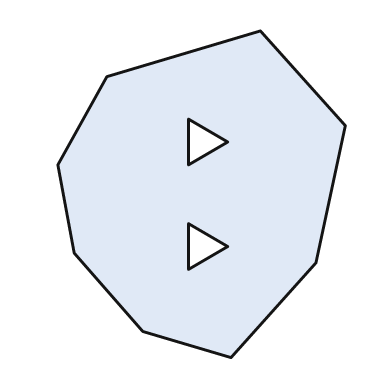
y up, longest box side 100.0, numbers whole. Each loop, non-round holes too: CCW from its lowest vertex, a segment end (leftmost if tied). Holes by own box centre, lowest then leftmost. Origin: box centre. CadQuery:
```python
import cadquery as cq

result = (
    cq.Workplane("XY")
    .moveTo(9.0, -50.0)
    .lineTo(35.0, -21.0)
    .lineTo(44.0, 21.0)
    .lineTo(18.0, 50.0)
    .lineTo(-29.0, 36.0)
    .lineTo(-44.0, 9.0)
    .lineTo(-39.0, -18.0)
    .lineTo(-18.0, -42.0)
    .close()
    .moveTo(-4.0, -23.0)
    .lineTo(8.0, -16.0)
    .lineTo(-4.0, -9.0)
    .close()
    .moveTo(-4.0, 9.0)
    .lineTo(8.0, 16.0)
    .lineTo(-4.0, 23.0)
    .close()
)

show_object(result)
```